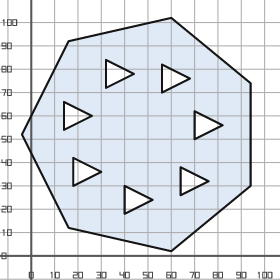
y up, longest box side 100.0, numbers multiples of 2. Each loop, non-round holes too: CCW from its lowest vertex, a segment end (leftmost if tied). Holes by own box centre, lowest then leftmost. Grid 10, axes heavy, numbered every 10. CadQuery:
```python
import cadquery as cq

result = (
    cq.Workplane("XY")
    .moveTo(60.0, 2.0)
    .lineTo(94.0, 30.0)
    .lineTo(94.0, 74.0)
    .lineTo(60.0, 102.0)
    .lineTo(16.0, 92.0)
    .lineTo(-4.0, 52.0)
    .lineTo(16.0, 12.0)
    .close()
    .moveTo(40.0, 18.0)
    .lineTo(52.0, 24.0)
    .lineTo(40.0, 30.0)
    .close()
    .moveTo(64.0, 26.0)
    .lineTo(76.0, 32.0)
    .lineTo(64.0, 38.0)
    .close()
    .moveTo(18.0, 30.0)
    .lineTo(30.0, 36.0)
    .lineTo(18.0, 42.0)
    .close()
    .moveTo(70.0, 50.0)
    .lineTo(82.0, 56.0)
    .lineTo(70.0, 62.0)
    .close()
    .moveTo(14.0, 54.0)
    .lineTo(26.0, 60.0)
    .lineTo(14.0, 66.0)
    .close()
    .moveTo(56.0, 70.0)
    .lineTo(68.0, 76.0)
    .lineTo(56.0, 82.0)
    .close()
    .moveTo(32.0, 72.0)
    .lineTo(44.0, 78.0)
    .lineTo(32.0, 84.0)
    .close()
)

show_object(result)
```